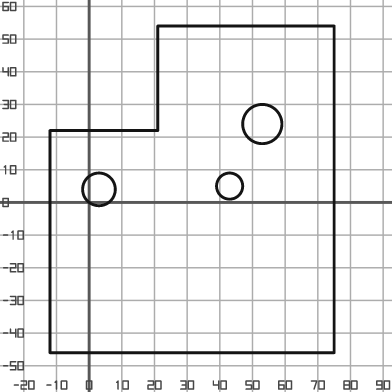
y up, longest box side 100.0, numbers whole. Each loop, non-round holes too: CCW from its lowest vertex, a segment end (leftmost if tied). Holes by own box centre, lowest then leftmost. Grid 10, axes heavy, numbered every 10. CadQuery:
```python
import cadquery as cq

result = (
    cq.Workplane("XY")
    .moveTo(-12.0, -46.0)
    .lineTo(75.0, -46.0)
    .lineTo(75.0, 54.0)
    .lineTo(21.0, 54.0)
    .lineTo(21.0, 22.0)
    .lineTo(-12.0, 22.0)
    .close()
    .moveTo(3.0, 4.0)
    .circle(5.0)
    .moveTo(43.0, 5.0)
    .circle(4.0)
    .moveTo(53.0, 24.0)
    .circle(6.0)
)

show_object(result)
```